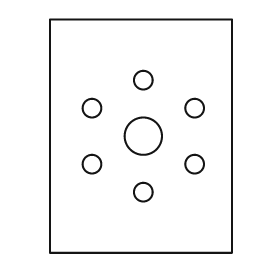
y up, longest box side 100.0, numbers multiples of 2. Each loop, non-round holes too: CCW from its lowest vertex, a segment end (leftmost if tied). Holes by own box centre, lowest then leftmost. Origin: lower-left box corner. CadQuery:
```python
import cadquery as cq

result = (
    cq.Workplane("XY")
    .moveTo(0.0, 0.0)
    .lineTo(78.0, 0.0)
    .lineTo(78.0, 100.0)
    .lineTo(0.0, 100.0)
    .close()
    .moveTo(40.0, 26.0)
    .circle(4.0)
    .moveTo(18.0, 38.0)
    .circle(4.0)
    .moveTo(62.0, 38.0)
    .circle(4.0)
    .moveTo(40.0, 50.0)
    .circle(8.0)
    .moveTo(18.0, 62.0)
    .circle(4.0)
    .moveTo(62.0, 62.0)
    .circle(4.0)
    .moveTo(40.0, 74.0)
    .circle(4.0)
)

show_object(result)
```